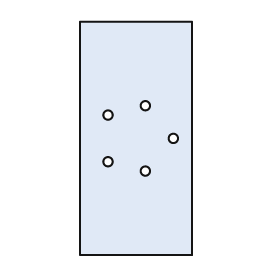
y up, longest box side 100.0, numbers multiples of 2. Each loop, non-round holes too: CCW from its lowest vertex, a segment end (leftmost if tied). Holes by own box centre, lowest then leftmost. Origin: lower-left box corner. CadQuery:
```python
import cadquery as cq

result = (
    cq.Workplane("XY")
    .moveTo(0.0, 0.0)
    .lineTo(48.0, 0.0)
    .lineTo(48.0, 100.0)
    .lineTo(0.0, 100.0)
    .close()
    .moveTo(28.0, 36.0)
    .circle(2.0)
    .moveTo(12.0, 40.0)
    .circle(2.0)
    .moveTo(40.0, 50.0)
    .circle(2.0)
    .moveTo(12.0, 60.0)
    .circle(2.0)
    .moveTo(28.0, 64.0)
    .circle(2.0)
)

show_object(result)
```